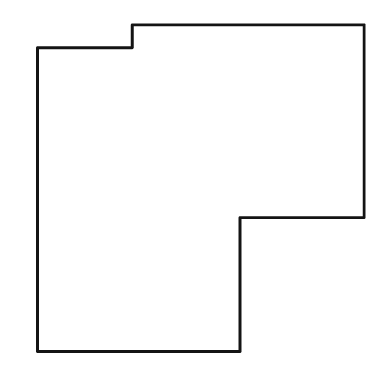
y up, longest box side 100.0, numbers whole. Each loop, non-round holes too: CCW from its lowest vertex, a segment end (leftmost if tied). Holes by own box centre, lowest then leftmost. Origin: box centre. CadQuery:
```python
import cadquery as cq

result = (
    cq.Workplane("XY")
    .moveTo(-50.0, -50.0)
    .lineTo(12.0, -50.0)
    .lineTo(12.0, -9.0)
    .lineTo(50.0, -9.0)
    .lineTo(50.0, 50.0)
    .lineTo(-21.0, 50.0)
    .lineTo(-21.0, 43.0)
    .lineTo(-50.0, 43.0)
    .close()
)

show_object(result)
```